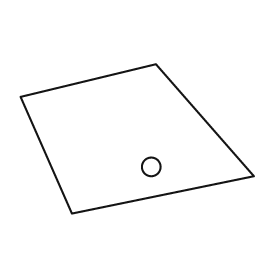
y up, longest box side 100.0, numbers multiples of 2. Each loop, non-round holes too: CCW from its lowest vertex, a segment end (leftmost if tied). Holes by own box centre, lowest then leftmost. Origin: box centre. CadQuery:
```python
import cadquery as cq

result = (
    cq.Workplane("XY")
    .moveTo(-28.0, -32.0)
    .lineTo(50.0, -16.0)
    .lineTo(8.0, 32.0)
    .lineTo(-50.0, 18.0)
    .close()
    .moveTo(6.0, -12.0)
    .circle(4.0)
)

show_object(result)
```